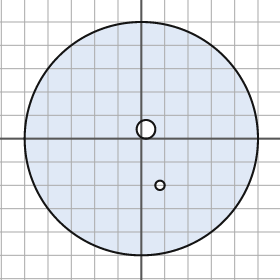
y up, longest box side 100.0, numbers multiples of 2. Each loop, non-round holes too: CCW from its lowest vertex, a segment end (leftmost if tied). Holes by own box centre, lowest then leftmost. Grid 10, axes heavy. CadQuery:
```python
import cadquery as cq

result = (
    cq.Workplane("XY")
    .moveTo(0.0, 0.0)
    .circle(50.0)
    .moveTo(8.0, -20.0)
    .circle(2.0)
    .moveTo(2.0, 4.0)
    .circle(4.0)
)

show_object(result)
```